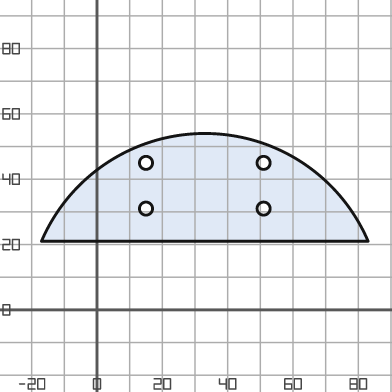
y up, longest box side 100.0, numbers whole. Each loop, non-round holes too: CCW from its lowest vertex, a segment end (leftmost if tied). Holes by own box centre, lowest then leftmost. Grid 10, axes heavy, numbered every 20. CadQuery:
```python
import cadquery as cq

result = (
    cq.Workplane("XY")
    .moveTo(-17.0, 21.0)
    .lineTo(83.0, 21.0)
    .threePointArc((33.0, 54.0), (-17.0, 21.0))
    .close()
    .moveTo(15.0, 31.0)
    .circle(2.0)
    .moveTo(51.0, 31.0)
    .circle(2.0)
    .moveTo(15.0, 45.0)
    .circle(2.0)
    .moveTo(51.0, 45.0)
    .circle(2.0)
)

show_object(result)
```